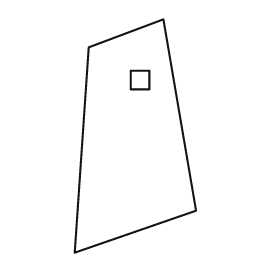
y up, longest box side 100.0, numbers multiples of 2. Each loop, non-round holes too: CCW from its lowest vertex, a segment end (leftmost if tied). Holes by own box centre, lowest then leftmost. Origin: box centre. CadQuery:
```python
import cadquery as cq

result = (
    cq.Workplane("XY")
    .moveTo(-26.0, -50.0)
    .lineTo(26.0, -32.0)
    .lineTo(12.0, 50.0)
    .lineTo(-20.0, 38.0)
    .close()
    .moveTo(-2.0, 20.0)
    .lineTo(6.0, 20.0)
    .lineTo(6.0, 28.0)
    .lineTo(-2.0, 28.0)
    .close()
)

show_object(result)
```